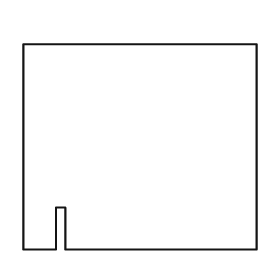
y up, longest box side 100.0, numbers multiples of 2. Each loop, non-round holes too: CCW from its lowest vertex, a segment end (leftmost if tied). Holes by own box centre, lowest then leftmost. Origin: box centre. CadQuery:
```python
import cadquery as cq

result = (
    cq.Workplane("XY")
    .moveTo(-50.0, -44.0)
    .lineTo(-36.0, -44.0)
    .lineTo(-36.0, -26.0)
    .lineTo(-32.0, -26.0)
    .lineTo(-32.0, -44.0)
    .lineTo(50.0, -44.0)
    .lineTo(50.0, 44.0)
    .lineTo(-50.0, 44.0)
    .close()
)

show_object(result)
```